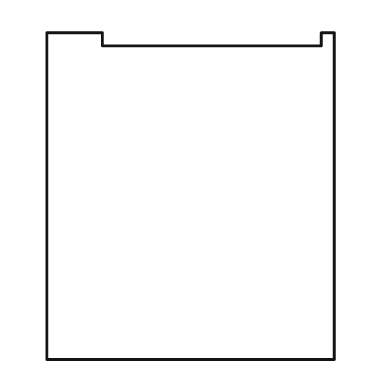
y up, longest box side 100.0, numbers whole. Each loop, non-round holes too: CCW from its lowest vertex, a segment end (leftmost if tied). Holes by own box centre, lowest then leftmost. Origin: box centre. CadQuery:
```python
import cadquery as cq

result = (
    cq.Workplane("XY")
    .moveTo(-44.0, -50.0)
    .lineTo(44.0, -50.0)
    .lineTo(44.0, 50.0)
    .lineTo(40.0, 50.0)
    .lineTo(40.0, 46.0)
    .lineTo(-27.0, 46.0)
    .lineTo(-27.0, 50.0)
    .lineTo(-44.0, 50.0)
    .close()
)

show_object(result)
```